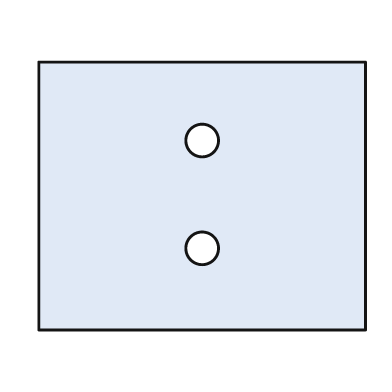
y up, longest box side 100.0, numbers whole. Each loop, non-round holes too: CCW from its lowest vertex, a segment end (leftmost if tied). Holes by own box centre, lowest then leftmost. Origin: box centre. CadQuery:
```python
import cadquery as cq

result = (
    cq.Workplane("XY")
    .moveTo(-50.0, -41.0)
    .lineTo(50.0, -41.0)
    .lineTo(50.0, 41.0)
    .lineTo(-50.0, 41.0)
    .close()
    .moveTo(0.0, -16.0)
    .circle(5.0)
    .moveTo(0.0, 17.0)
    .circle(5.0)
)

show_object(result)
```